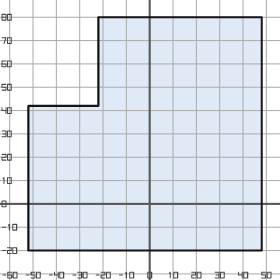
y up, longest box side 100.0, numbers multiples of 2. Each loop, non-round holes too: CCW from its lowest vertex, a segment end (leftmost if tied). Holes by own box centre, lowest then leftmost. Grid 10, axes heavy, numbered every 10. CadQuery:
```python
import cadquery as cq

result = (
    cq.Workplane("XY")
    .moveTo(-52.0, -20.0)
    .lineTo(48.0, -20.0)
    .lineTo(48.0, 80.0)
    .lineTo(-22.0, 80.0)
    .lineTo(-22.0, 42.0)
    .lineTo(-52.0, 42.0)
    .close()
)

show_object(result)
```